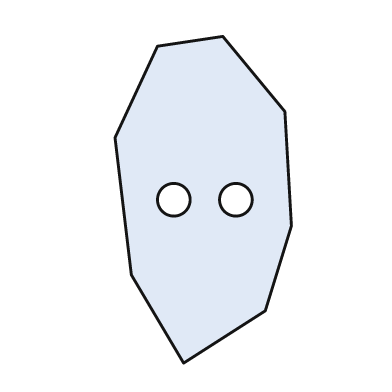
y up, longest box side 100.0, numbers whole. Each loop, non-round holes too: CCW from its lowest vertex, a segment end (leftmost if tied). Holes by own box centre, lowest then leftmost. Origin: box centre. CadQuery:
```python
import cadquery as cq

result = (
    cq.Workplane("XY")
    .moveTo(-6.0, -50.0)
    .lineTo(19.0, -34.0)
    .lineTo(27.0, -8.0)
    .lineTo(25.0, 27.0)
    .lineTo(6.0, 50.0)
    .lineTo(-14.0, 47.0)
    .lineTo(-27.0, 19.0)
    .lineTo(-22.0, -23.0)
    .close()
    .moveTo(-9.0, 0.0)
    .circle(5.0)
    .moveTo(10.0, 0.0)
    .circle(5.0)
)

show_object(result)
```